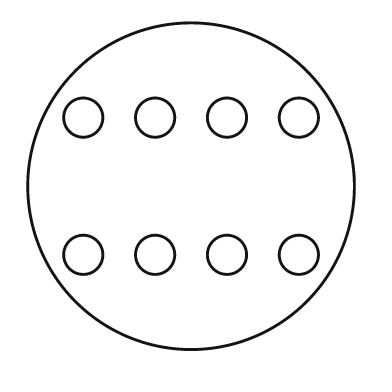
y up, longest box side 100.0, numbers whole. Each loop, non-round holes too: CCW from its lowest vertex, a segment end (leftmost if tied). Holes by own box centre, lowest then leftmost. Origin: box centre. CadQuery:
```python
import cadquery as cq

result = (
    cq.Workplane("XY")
    .moveTo(0.0, 0.0)
    .circle(50.0)
    .moveTo(-33.0, -21.0)
    .circle(6.0)
    .moveTo(-11.0, -21.0)
    .circle(6.0)
    .moveTo(11.0, -21.0)
    .circle(6.0)
    .moveTo(33.0, -21.0)
    .circle(6.0)
    .moveTo(-33.0, 21.0)
    .circle(6.0)
    .moveTo(-11.0, 21.0)
    .circle(6.0)
    .moveTo(11.0, 21.0)
    .circle(6.0)
    .moveTo(33.0, 21.0)
    .circle(6.0)
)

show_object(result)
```